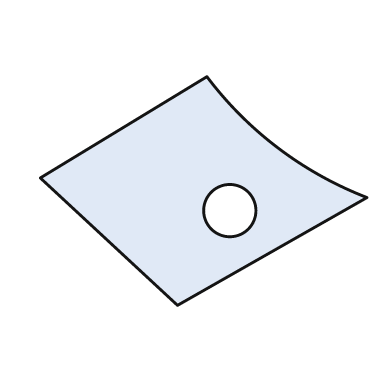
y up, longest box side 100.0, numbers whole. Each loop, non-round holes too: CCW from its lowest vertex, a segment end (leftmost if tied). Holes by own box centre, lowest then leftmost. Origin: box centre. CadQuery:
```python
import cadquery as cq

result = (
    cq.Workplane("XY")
    .moveTo(-8.0, -35.0)
    .lineTo(50.0, -2.0)
    .threePointArc((23.0, 13.0), (1.0, 35.0))
    .lineTo(-50.0, 4.0)
    .close()
    .moveTo(8.0, -6.0)
    .circle(8.0)
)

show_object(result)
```